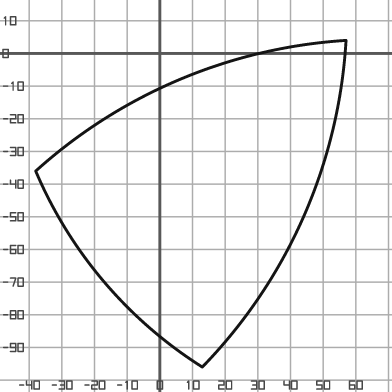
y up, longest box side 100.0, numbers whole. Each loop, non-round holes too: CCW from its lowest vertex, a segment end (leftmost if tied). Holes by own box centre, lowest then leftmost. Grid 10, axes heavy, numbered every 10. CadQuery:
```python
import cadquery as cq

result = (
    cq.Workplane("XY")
    .moveTo(13.0, -96.0)
    .threePointArc((44.0, -50.0), (57.0, 4.0))
    .threePointArc((6.0, -8.0), (-38.0, -36.0))
    .threePointArc((-17.0, -70.0), (13.0, -96.0))
    .close()
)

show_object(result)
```